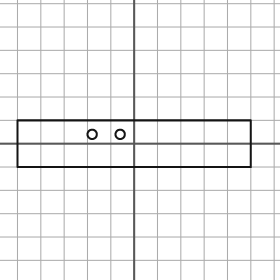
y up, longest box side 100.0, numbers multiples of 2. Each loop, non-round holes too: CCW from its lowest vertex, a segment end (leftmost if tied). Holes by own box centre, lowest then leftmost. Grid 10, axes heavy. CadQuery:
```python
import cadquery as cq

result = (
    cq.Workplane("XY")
    .moveTo(-50.0, -10.0)
    .lineTo(50.0, -10.0)
    .lineTo(50.0, 10.0)
    .lineTo(-50.0, 10.0)
    .close()
    .moveTo(-18.0, 4.0)
    .circle(2.0)
    .moveTo(-6.0, 4.0)
    .circle(2.0)
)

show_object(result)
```